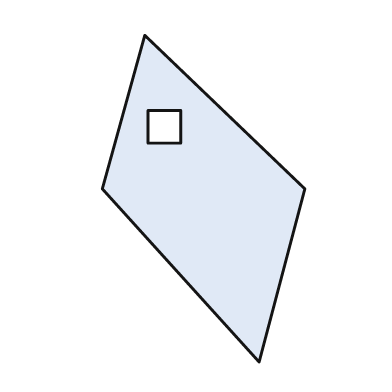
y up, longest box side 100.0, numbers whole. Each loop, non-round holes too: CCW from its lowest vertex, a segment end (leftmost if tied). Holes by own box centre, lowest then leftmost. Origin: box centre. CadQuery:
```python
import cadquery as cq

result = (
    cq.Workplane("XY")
    .moveTo(17.0, -50.0)
    .lineTo(31.0, 3.0)
    .lineTo(-18.0, 50.0)
    .lineTo(-31.0, 3.0)
    .close()
    .moveTo(-17.0, 17.0)
    .lineTo(-7.0, 17.0)
    .lineTo(-7.0, 27.0)
    .lineTo(-17.0, 27.0)
    .close()
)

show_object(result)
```